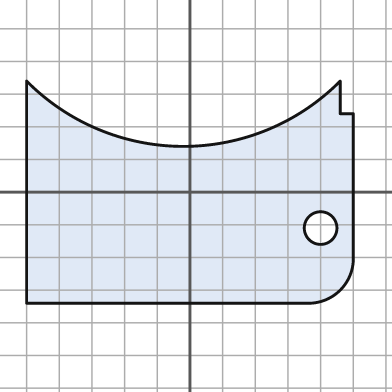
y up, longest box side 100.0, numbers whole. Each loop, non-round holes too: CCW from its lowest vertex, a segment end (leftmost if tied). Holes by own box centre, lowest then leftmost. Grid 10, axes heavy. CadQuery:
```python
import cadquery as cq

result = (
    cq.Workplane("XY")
    .moveTo(-50.0, -34.0)
    .lineTo(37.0, -34.0)
    .threePointArc((46.0, -30.0), (50.0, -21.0))
    .lineTo(50.0, 24.0)
    .lineTo(46.0, 24.0)
    .lineTo(46.0, 34.0)
    .threePointArc((-2.0, 14.0), (-50.0, 34.0))
    .close()
    .moveTo(40.0, -11.0)
    .circle(5.0)
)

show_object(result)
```